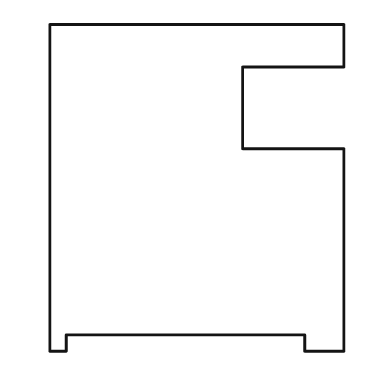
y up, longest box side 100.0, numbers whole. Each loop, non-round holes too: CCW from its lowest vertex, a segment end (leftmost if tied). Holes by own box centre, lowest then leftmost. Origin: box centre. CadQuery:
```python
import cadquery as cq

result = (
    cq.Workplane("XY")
    .moveTo(-45.0, -50.0)
    .lineTo(-40.0, -50.0)
    .lineTo(-40.0, -45.0)
    .lineTo(33.0, -45.0)
    .lineTo(33.0, -50.0)
    .lineTo(45.0, -50.0)
    .lineTo(45.0, 12.0)
    .lineTo(14.0, 12.0)
    .lineTo(14.0, 37.0)
    .lineTo(45.0, 37.0)
    .lineTo(45.0, 50.0)
    .lineTo(-45.0, 50.0)
    .close()
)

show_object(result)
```